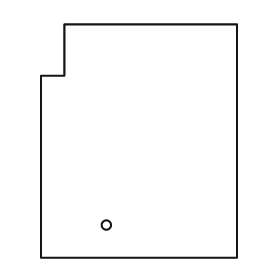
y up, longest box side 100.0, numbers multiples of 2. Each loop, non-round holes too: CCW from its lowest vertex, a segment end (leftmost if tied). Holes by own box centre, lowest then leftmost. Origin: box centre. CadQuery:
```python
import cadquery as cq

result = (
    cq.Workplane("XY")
    .moveTo(-42.0, -50.0)
    .lineTo(42.0, -50.0)
    .lineTo(42.0, 50.0)
    .lineTo(-32.0, 50.0)
    .lineTo(-32.0, 28.0)
    .lineTo(-42.0, 28.0)
    .close()
    .moveTo(-14.0, -36.0)
    .circle(2.0)
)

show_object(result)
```